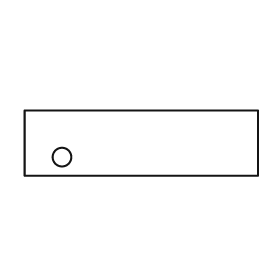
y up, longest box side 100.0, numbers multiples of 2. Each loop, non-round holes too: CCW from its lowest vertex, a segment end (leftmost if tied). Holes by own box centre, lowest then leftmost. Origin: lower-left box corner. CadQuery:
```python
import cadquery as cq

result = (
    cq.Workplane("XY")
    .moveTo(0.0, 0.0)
    .lineTo(100.0, 0.0)
    .lineTo(100.0, 28.0)
    .lineTo(0.0, 28.0)
    .close()
    .moveTo(16.0, 8.0)
    .circle(4.0)
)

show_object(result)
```